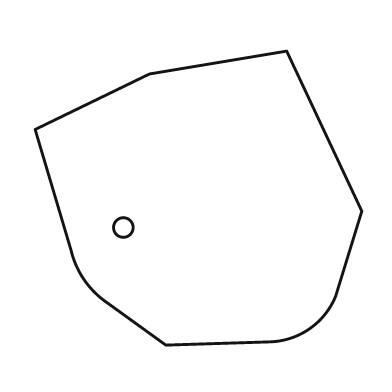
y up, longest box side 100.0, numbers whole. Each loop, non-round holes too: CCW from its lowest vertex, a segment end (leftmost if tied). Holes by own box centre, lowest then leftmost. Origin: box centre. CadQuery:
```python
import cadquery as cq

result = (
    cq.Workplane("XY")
    .moveTo(-10.0, -45.0)
    .lineTo(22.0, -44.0)
    .threePointArc((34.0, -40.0), (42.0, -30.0))
    .lineTo(50.0, -4.0)
    .lineTo(27.0, 45.0)
    .lineTo(-15.0, 38.0)
    .lineTo(-50.0, 21.0)
    .lineTo(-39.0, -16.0)
    .threePointArc((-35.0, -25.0), (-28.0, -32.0))
    .close()
    .moveTo(-23.0, -9.0)
    .circle(3.0)
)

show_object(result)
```